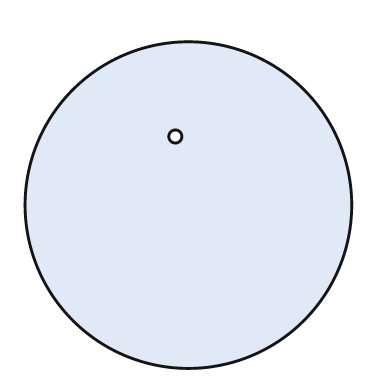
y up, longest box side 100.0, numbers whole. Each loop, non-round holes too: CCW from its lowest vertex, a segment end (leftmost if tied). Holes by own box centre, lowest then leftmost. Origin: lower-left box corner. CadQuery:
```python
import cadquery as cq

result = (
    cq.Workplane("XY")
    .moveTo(50.0, 50.0)
    .circle(50.0)
    .moveTo(46.0, 71.0)
    .circle(2.0)
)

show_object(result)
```